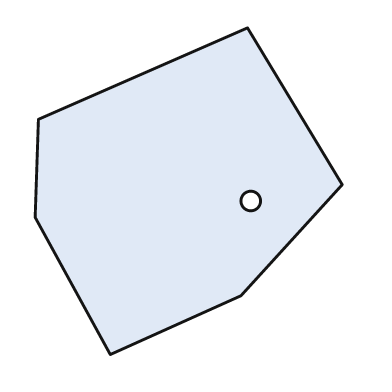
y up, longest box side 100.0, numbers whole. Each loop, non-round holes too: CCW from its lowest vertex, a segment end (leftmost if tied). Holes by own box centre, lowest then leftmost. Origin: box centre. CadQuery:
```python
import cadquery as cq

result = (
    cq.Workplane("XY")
    .moveTo(-24.0, -50.0)
    .lineTo(16.0, -32.0)
    .lineTo(47.0, 2.0)
    .lineTo(18.0, 50.0)
    .lineTo(-46.0, 22.0)
    .lineTo(-47.0, -8.0)
    .close()
    .moveTo(19.0, -3.0)
    .circle(3.0)
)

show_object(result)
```